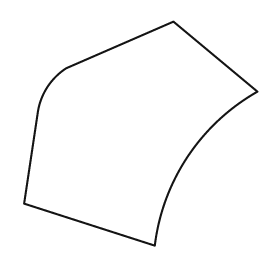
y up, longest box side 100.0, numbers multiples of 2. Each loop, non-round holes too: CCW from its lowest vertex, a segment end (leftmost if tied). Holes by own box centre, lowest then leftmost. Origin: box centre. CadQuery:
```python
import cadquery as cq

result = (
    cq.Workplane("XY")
    .moveTo(6.0, -48.0)
    .threePointArc((20.0, -10.0), (50.0, 18.0))
    .lineTo(14.0, 48.0)
    .lineTo(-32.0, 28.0)
    .threePointArc((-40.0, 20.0), (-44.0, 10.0))
    .lineTo(-50.0, -30.0)
    .close()
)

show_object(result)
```